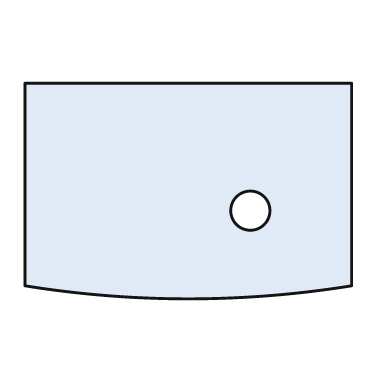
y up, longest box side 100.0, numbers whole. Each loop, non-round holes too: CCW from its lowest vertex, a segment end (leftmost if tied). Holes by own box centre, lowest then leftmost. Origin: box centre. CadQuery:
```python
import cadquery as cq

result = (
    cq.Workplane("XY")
    .moveTo(-50.0, -29.0)
    .threePointArc((0.0, -33.0), (50.0, -29.0))
    .lineTo(50.0, 33.0)
    .lineTo(-50.0, 33.0)
    .close()
    .moveTo(19.0, -6.0)
    .circle(6.0)
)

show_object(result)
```